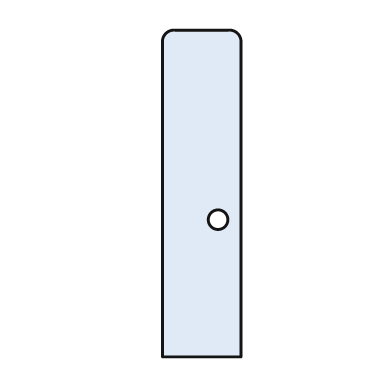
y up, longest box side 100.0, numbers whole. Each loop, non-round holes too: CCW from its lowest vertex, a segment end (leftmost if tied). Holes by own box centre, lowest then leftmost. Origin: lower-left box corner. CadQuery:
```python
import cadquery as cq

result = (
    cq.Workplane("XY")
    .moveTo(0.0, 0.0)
    .lineTo(24.0, 0.0)
    .lineTo(24.0, 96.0)
    .threePointArc((23.0, 99.0), (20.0, 100.0))
    .lineTo(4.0, 100.0)
    .threePointArc((1.0, 99.0), (0.0, 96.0))
    .close()
    .moveTo(17.0, 42.0)
    .circle(3.0)
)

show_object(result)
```